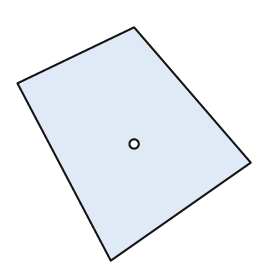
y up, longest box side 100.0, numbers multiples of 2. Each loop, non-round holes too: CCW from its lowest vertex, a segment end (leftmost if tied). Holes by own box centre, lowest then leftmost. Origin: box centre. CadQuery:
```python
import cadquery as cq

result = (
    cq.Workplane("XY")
    .moveTo(-10.0, -50.0)
    .lineTo(50.0, -8.0)
    .lineTo(0.0, 50.0)
    .lineTo(-50.0, 26.0)
    .close()
    .moveTo(0.0, 0.0)
    .circle(2.0)
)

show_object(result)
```